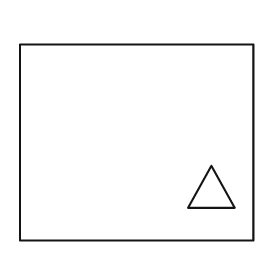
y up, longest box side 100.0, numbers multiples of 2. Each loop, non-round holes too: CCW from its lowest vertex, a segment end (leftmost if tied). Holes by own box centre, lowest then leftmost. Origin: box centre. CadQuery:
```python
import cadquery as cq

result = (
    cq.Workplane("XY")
    .moveTo(-50.0, -42.0)
    .lineTo(50.0, -42.0)
    .lineTo(50.0, 42.0)
    .lineTo(-50.0, 42.0)
    .close()
    .moveTo(22.0, -28.0)
    .lineTo(42.0, -28.0)
    .lineTo(32.0, -10.0)
    .close()
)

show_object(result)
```